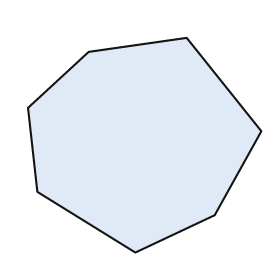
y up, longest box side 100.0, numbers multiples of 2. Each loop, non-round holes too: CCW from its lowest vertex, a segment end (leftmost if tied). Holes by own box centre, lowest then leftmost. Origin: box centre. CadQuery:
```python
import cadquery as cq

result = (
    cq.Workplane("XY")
    .moveTo(-4.0, -46.0)
    .lineTo(30.0, -30.0)
    .lineTo(50.0, 6.0)
    .lineTo(18.0, 46.0)
    .lineTo(-24.0, 40.0)
    .lineTo(-50.0, 16.0)
    .lineTo(-46.0, -20.0)
    .close()
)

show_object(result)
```